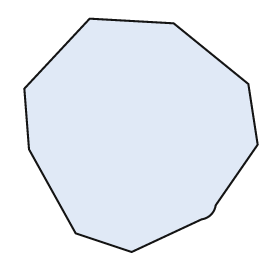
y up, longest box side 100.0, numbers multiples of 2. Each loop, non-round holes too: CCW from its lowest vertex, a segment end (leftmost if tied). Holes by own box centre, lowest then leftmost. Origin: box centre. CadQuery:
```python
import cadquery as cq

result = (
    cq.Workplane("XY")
    .moveTo(-4.0, -50.0)
    .lineTo(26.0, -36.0)
    .threePointArc((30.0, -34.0), (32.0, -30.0))
    .lineTo(50.0, -4.0)
    .lineTo(46.0, 22.0)
    .lineTo(14.0, 48.0)
    .lineTo(-22.0, 50.0)
    .lineTo(-50.0, 20.0)
    .lineTo(-48.0, -6.0)
    .lineTo(-28.0, -42.0)
    .close()
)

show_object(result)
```